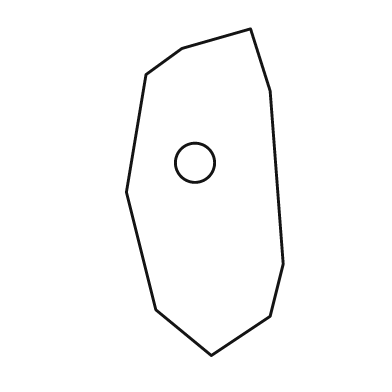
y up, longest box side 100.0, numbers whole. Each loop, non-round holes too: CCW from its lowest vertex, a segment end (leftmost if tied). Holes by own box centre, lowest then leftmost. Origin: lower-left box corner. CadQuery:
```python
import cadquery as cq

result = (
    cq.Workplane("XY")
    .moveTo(26.0, 0.0)
    .lineTo(44.0, 12.0)
    .lineTo(48.0, 28.0)
    .lineTo(44.0, 81.0)
    .lineTo(38.0, 100.0)
    .lineTo(17.0, 94.0)
    .lineTo(6.0, 86.0)
    .lineTo(0.0, 50.0)
    .lineTo(9.0, 14.0)
    .close()
    .moveTo(21.0, 59.0)
    .circle(6.0)
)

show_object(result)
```